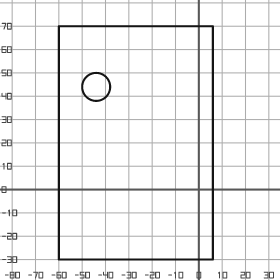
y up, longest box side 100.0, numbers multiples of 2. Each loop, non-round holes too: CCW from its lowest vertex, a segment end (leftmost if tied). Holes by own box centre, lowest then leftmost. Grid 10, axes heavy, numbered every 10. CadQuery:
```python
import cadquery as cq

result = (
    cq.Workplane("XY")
    .moveTo(-60.0, -30.0)
    .lineTo(6.0, -30.0)
    .lineTo(6.0, 70.0)
    .lineTo(-60.0, 70.0)
    .close()
    .moveTo(-44.0, 44.0)
    .circle(6.0)
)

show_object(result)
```